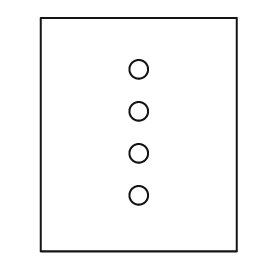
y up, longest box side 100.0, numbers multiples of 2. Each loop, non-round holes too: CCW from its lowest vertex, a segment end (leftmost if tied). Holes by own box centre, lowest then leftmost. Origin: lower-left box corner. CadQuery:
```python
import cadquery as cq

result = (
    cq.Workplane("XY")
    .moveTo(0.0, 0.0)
    .lineTo(84.0, 0.0)
    .lineTo(84.0, 100.0)
    .lineTo(0.0, 100.0)
    .close()
    .moveTo(42.0, 24.0)
    .circle(4.0)
    .moveTo(42.0, 42.0)
    .circle(4.0)
    .moveTo(42.0, 60.0)
    .circle(4.0)
    .moveTo(42.0, 78.0)
    .circle(4.0)
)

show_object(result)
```